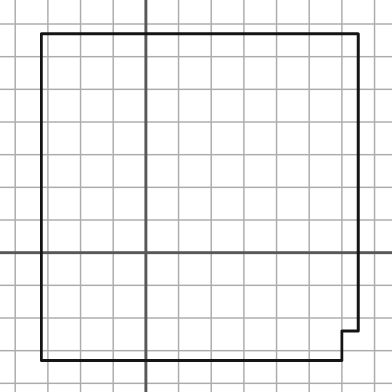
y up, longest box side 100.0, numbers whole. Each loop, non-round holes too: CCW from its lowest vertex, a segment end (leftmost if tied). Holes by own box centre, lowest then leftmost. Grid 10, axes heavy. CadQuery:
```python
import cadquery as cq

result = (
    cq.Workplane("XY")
    .moveTo(-32.0, -33.0)
    .lineTo(60.0, -33.0)
    .lineTo(60.0, -24.0)
    .lineTo(65.0, -24.0)
    .lineTo(65.0, 67.0)
    .lineTo(-32.0, 67.0)
    .close()
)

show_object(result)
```